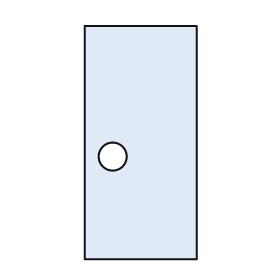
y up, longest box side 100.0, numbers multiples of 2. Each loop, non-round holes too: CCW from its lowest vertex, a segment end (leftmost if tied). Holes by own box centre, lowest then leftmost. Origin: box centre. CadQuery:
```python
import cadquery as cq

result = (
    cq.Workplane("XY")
    .moveTo(-24.0, -50.0)
    .lineTo(24.0, -50.0)
    .lineTo(24.0, 50.0)
    .lineTo(-24.0, 50.0)
    .close()
    .moveTo(-12.0, -6.0)
    .circle(6.0)
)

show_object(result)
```